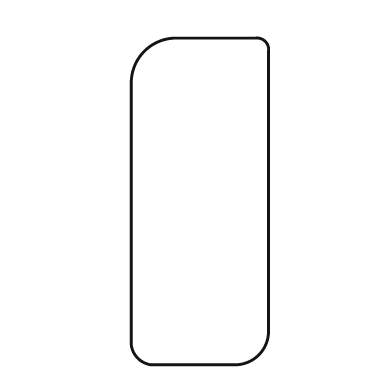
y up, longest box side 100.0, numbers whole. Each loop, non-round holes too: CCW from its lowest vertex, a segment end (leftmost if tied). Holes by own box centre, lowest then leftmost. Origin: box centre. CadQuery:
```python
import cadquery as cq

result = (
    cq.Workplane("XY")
    .moveTo(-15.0, -50.0)
    .lineTo(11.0, -50.0)
    .threePointArc((18.0, -47.0), (21.0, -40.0))
    .lineTo(21.0, 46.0)
    .threePointArc((20.0, 49.0), (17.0, 50.0))
    .lineTo(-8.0, 50.0)
    .threePointArc((-17.0, 46.0), (-21.0, 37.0))
    .lineTo(-21.0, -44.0)
    .threePointArc((-19.0, -48.0), (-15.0, -50.0))
    .close()
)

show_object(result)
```